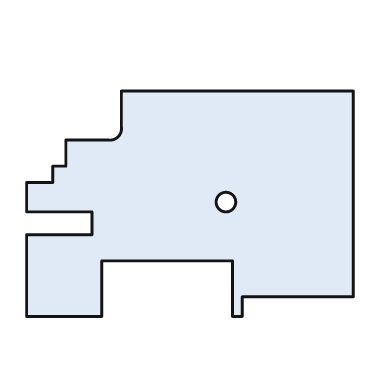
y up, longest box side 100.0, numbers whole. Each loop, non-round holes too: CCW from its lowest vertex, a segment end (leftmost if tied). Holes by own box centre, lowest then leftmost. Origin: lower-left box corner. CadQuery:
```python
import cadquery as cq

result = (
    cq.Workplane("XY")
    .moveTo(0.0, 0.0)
    .lineTo(23.0, 0.0)
    .lineTo(23.0, 17.0)
    .lineTo(63.0, 17.0)
    .lineTo(63.0, 0.0)
    .lineTo(66.0, 0.0)
    .lineTo(66.0, 6.0)
    .lineTo(100.0, 6.0)
    .lineTo(100.0, 69.0)
    .lineTo(29.0, 69.0)
    .lineTo(29.0, 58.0)
    .threePointArc((28.0, 55.0), (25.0, 54.0))
    .lineTo(12.0, 54.0)
    .lineTo(12.0, 46.0)
    .lineTo(8.0, 46.0)
    .lineTo(8.0, 41.0)
    .lineTo(0.0, 41.0)
    .lineTo(0.0, 32.0)
    .lineTo(20.0, 32.0)
    .lineTo(20.0, 25.0)
    .lineTo(0.0, 25.0)
    .close()
    .moveTo(61.0, 35.0)
    .circle(3.0)
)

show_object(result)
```